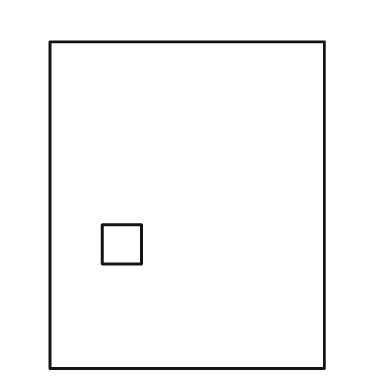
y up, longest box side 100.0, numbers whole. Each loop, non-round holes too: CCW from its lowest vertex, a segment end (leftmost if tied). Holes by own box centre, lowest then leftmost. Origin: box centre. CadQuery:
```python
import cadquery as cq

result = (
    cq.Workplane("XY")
    .moveTo(-42.0, -50.0)
    .lineTo(42.0, -50.0)
    .lineTo(42.0, 50.0)
    .lineTo(-42.0, 50.0)
    .close()
    .moveTo(-26.0, -18.0)
    .lineTo(-14.0, -18.0)
    .lineTo(-14.0, -6.0)
    .lineTo(-26.0, -6.0)
    .close()
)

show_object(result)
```